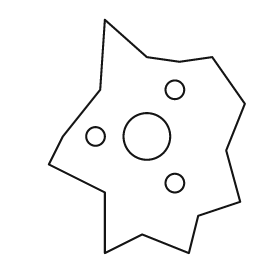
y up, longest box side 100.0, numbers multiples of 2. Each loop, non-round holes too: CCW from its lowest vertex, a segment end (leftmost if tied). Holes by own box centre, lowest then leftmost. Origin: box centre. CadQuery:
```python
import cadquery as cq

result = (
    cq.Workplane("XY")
    .moveTo(-18.0, -50.0)
    .lineTo(-2.0, -42.0)
    .lineTo(18.0, -50.0)
    .lineTo(22.0, -34.0)
    .lineTo(40.0, -28.0)
    .lineTo(34.0, -6.0)
    .lineTo(42.0, 14.0)
    .lineTo(28.0, 34.0)
    .lineTo(14.0, 32.0)
    .lineTo(0.0, 34.0)
    .lineTo(-18.0, 50.0)
    .lineTo(-20.0, 20.0)
    .lineTo(-36.0, 0.0)
    .lineTo(-42.0, -12.0)
    .lineTo(-18.0, -24.0)
    .close()
    .moveTo(12.0, -20.0)
    .circle(4.0)
    .moveTo(-22.0, 0.0)
    .circle(4.0)
    .moveTo(0.0, 0.0)
    .circle(10.0)
    .moveTo(12.0, 20.0)
    .circle(4.0)
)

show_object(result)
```